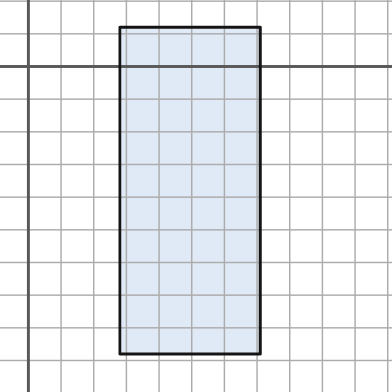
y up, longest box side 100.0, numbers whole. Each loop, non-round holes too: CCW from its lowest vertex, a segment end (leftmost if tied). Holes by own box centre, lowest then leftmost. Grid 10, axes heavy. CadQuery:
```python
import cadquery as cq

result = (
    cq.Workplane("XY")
    .moveTo(28.0, -88.0)
    .lineTo(71.0, -88.0)
    .lineTo(71.0, 12.0)
    .lineTo(28.0, 12.0)
    .close()
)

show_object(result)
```